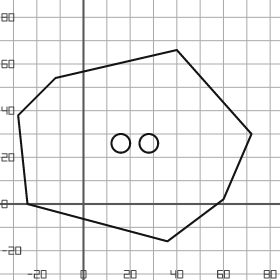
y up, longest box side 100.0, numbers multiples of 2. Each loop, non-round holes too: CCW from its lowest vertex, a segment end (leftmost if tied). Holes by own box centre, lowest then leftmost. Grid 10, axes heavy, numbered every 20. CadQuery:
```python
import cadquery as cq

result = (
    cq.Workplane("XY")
    .moveTo(36.0, -16.0)
    .lineTo(60.0, 2.0)
    .lineTo(72.0, 30.0)
    .lineTo(40.0, 66.0)
    .lineTo(-12.0, 54.0)
    .lineTo(-28.0, 38.0)
    .lineTo(-24.0, 0.0)
    .close()
    .moveTo(16.0, 26.0)
    .circle(4.0)
    .moveTo(28.0, 26.0)
    .circle(4.0)
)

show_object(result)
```